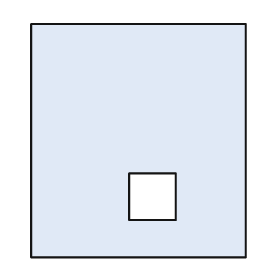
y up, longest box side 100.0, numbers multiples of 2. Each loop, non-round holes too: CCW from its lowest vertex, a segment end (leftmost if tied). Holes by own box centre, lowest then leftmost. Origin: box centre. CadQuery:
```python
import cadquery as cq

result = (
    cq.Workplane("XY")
    .moveTo(-46.0, -50.0)
    .lineTo(46.0, -50.0)
    .lineTo(46.0, 50.0)
    .lineTo(-46.0, 50.0)
    .close()
    .moveTo(-4.0, -34.0)
    .lineTo(16.0, -34.0)
    .lineTo(16.0, -14.0)
    .lineTo(-4.0, -14.0)
    .close()
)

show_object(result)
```